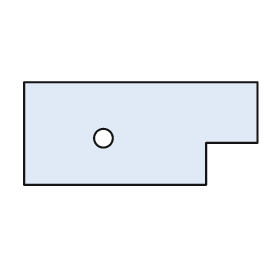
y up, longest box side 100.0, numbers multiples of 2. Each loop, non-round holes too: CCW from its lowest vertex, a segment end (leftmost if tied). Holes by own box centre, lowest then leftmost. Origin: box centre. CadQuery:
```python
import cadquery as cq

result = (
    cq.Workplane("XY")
    .moveTo(-50.0, -22.0)
    .lineTo(28.0, -22.0)
    .lineTo(28.0, -4.0)
    .lineTo(50.0, -4.0)
    .lineTo(50.0, 22.0)
    .lineTo(-50.0, 22.0)
    .close()
    .moveTo(-16.0, -2.0)
    .circle(4.0)
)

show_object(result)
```